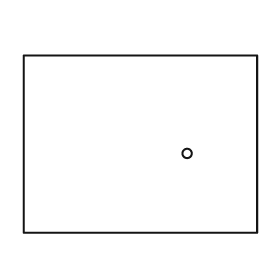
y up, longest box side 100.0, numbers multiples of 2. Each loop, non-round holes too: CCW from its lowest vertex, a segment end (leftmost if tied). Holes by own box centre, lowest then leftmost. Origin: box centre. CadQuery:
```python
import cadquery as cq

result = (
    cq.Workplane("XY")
    .moveTo(-50.0, -38.0)
    .lineTo(50.0, -38.0)
    .lineTo(50.0, 38.0)
    .lineTo(-50.0, 38.0)
    .close()
    .moveTo(20.0, -4.0)
    .circle(2.0)
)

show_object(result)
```